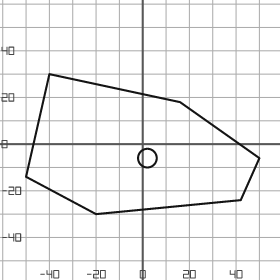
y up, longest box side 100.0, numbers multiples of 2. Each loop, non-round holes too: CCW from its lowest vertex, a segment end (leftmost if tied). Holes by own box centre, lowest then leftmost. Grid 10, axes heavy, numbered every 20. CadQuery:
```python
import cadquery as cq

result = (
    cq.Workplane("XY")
    .moveTo(-20.0, -30.0)
    .lineTo(42.0, -24.0)
    .lineTo(50.0, -6.0)
    .lineTo(16.0, 18.0)
    .lineTo(-40.0, 30.0)
    .lineTo(-50.0, -14.0)
    .close()
    .moveTo(2.0, -6.0)
    .circle(4.0)
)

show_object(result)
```